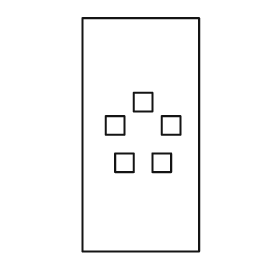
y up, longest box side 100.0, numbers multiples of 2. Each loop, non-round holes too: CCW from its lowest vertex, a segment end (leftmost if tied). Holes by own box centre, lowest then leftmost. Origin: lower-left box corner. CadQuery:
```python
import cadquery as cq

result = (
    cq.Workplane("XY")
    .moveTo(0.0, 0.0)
    .lineTo(50.0, 0.0)
    .lineTo(50.0, 100.0)
    .lineTo(0.0, 100.0)
    .close()
    .moveTo(14.0, 34.0)
    .lineTo(22.0, 34.0)
    .lineTo(22.0, 42.0)
    .lineTo(14.0, 42.0)
    .close()
    .moveTo(30.0, 34.0)
    .lineTo(38.0, 34.0)
    .lineTo(38.0, 42.0)
    .lineTo(30.0, 42.0)
    .close()
    .moveTo(10.0, 50.0)
    .lineTo(18.0, 50.0)
    .lineTo(18.0, 58.0)
    .lineTo(10.0, 58.0)
    .close()
    .moveTo(34.0, 50.0)
    .lineTo(42.0, 50.0)
    .lineTo(42.0, 58.0)
    .lineTo(34.0, 58.0)
    .close()
    .moveTo(22.0, 60.0)
    .lineTo(30.0, 60.0)
    .lineTo(30.0, 68.0)
    .lineTo(22.0, 68.0)
    .close()
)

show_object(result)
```